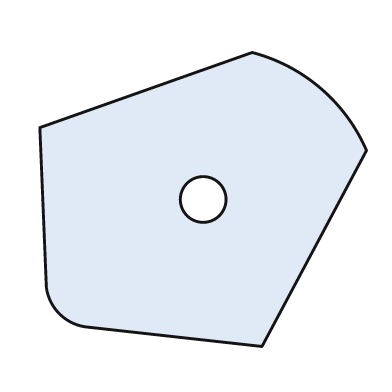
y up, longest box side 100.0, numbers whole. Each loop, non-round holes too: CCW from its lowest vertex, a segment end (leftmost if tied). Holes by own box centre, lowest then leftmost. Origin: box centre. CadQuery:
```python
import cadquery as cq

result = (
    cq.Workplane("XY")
    .moveTo(18.0, -45.0)
    .lineTo(50.0, 15.0)
    .threePointArc((36.0, 34.0), (15.0, 45.0))
    .lineTo(-50.0, 22.0)
    .lineTo(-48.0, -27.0)
    .threePointArc((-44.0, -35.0), (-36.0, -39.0))
    .close()
    .moveTo(0.0, 0.0)
    .circle(7.0)
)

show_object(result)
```